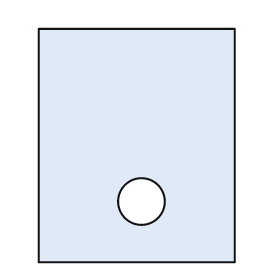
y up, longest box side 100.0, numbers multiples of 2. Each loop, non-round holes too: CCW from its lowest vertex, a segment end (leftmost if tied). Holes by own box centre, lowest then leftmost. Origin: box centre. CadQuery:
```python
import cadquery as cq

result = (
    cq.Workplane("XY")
    .moveTo(-42.0, -50.0)
    .lineTo(42.0, -50.0)
    .lineTo(42.0, 50.0)
    .lineTo(-42.0, 50.0)
    .close()
    .moveTo(2.0, -24.0)
    .circle(10.0)
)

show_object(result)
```